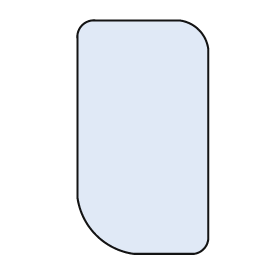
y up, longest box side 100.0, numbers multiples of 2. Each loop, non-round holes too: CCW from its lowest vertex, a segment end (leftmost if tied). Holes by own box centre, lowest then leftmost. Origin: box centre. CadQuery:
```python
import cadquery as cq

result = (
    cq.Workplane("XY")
    .moveTo(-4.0, -50.0)
    .lineTo(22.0, -50.0)
    .threePointArc((26.0, -48.0), (28.0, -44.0))
    .lineTo(28.0, 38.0)
    .threePointArc((24.0, 46.0), (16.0, 50.0))
    .lineTo(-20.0, 50.0)
    .threePointArc((-26.0, 48.0), (-28.0, 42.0))
    .lineTo(-28.0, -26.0)
    .threePointArc((-20.0, -42.0), (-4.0, -50.0))
    .close()
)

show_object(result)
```